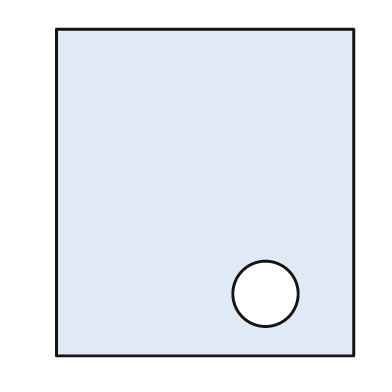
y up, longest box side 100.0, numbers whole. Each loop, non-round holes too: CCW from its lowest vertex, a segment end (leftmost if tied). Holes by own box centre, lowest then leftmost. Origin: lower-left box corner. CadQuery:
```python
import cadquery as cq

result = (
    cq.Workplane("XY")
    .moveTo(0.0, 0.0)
    .lineTo(91.0, 0.0)
    .lineTo(91.0, 100.0)
    .lineTo(0.0, 100.0)
    .close()
    .moveTo(64.0, 19.0)
    .circle(10.0)
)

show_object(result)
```